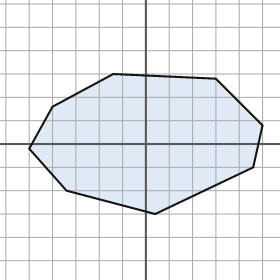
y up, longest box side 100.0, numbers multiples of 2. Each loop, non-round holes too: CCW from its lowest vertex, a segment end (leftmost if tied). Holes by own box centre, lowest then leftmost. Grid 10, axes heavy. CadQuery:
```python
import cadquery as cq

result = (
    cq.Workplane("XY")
    .moveTo(4.0, -30.0)
    .lineTo(46.0, -10.0)
    .lineTo(50.0, 8.0)
    .lineTo(30.0, 28.0)
    .lineTo(-14.0, 30.0)
    .lineTo(-40.0, 16.0)
    .lineTo(-50.0, -2.0)
    .lineTo(-34.0, -20.0)
    .close()
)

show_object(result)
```